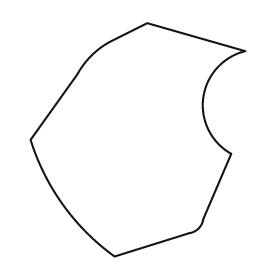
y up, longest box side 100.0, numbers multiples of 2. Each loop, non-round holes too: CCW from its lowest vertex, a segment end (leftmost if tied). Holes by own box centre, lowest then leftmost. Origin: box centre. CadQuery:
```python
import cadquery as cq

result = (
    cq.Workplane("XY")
    .moveTo(-10.0, -50.0)
    .lineTo(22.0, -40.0)
    .threePointArc((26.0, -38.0), (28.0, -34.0))
    .lineTo(40.0, -6.0)
    .threePointArc((28.0, 18.0), (46.0, 38.0))
    .lineTo(4.0, 50.0)
    .lineTo(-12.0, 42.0)
    .threePointArc((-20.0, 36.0), (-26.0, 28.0))
    .lineTo(-46.0, 0.0)
    .threePointArc((-32.0, -28.0), (-10.0, -50.0))
    .close()
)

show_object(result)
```